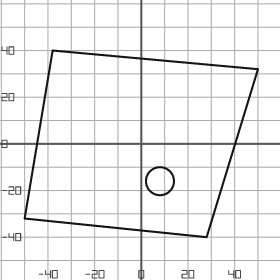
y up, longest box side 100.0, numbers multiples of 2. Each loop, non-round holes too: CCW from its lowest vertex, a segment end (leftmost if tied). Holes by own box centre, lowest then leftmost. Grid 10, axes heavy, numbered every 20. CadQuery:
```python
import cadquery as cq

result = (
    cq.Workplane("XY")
    .moveTo(28.0, -40.0)
    .lineTo(50.0, 32.0)
    .lineTo(-38.0, 40.0)
    .lineTo(-50.0, -32.0)
    .close()
    .moveTo(8.0, -16.0)
    .circle(6.0)
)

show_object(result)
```